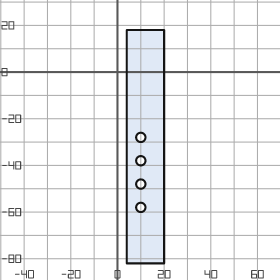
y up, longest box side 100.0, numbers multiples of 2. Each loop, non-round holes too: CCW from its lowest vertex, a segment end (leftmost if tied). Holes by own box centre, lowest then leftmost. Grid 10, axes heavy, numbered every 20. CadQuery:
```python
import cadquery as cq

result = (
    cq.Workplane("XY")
    .moveTo(4.0, -82.0)
    .lineTo(20.0, -82.0)
    .lineTo(20.0, 18.0)
    .lineTo(4.0, 18.0)
    .close()
    .moveTo(10.0, -58.0)
    .circle(2.0)
    .moveTo(10.0, -48.0)
    .circle(2.0)
    .moveTo(10.0, -38.0)
    .circle(2.0)
    .moveTo(10.0, -28.0)
    .circle(2.0)
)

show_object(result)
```